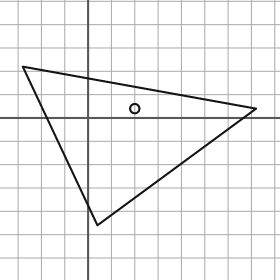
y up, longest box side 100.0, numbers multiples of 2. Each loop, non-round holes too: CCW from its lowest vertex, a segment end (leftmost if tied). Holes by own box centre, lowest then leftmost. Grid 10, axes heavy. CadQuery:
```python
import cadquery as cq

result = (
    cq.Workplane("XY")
    .moveTo(4.0, -46.0)
    .lineTo(72.0, 4.0)
    .lineTo(-28.0, 22.0)
    .close()
    .moveTo(20.0, 4.0)
    .circle(2.0)
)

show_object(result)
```